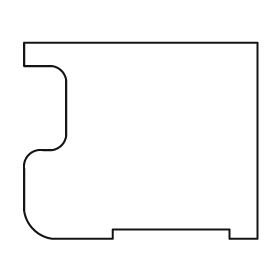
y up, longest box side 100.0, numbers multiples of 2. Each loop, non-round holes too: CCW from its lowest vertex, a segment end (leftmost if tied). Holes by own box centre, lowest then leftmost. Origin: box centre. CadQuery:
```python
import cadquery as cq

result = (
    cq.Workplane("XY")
    .moveTo(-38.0, -42.0)
    .lineTo(-12.0, -42.0)
    .lineTo(-12.0, -38.0)
    .lineTo(38.0, -38.0)
    .lineTo(38.0, -42.0)
    .lineTo(50.0, -42.0)
    .lineTo(50.0, 42.0)
    .lineTo(-50.0, 42.0)
    .lineTo(-50.0, 32.0)
    .lineTo(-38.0, 32.0)
    .threePointArc((-34.0, 30.0), (-32.0, 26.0))
    .lineTo(-32.0, 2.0)
    .threePointArc((-34.0, -2.0), (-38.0, -4.0))
    .lineTo(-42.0, -4.0)
    .threePointArc((-48.0, -6.0), (-50.0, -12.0))
    .lineTo(-50.0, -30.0)
    .threePointArc((-46.0, -38.0), (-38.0, -42.0))
    .close()
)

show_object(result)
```